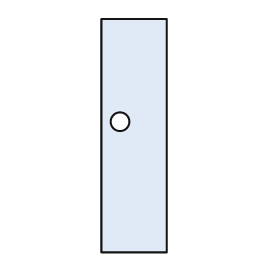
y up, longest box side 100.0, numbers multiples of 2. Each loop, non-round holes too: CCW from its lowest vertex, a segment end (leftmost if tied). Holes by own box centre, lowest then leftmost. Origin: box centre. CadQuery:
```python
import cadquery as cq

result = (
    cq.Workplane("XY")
    .moveTo(-14.0, -50.0)
    .lineTo(14.0, -50.0)
    .lineTo(14.0, 50.0)
    .lineTo(-14.0, 50.0)
    .close()
    .moveTo(-6.0, 6.0)
    .circle(4.0)
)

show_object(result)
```